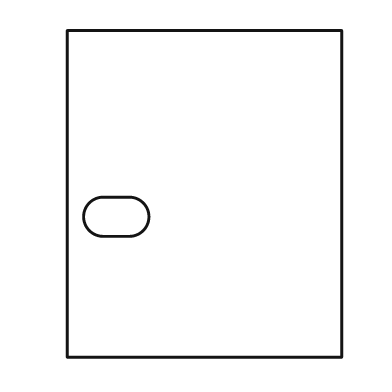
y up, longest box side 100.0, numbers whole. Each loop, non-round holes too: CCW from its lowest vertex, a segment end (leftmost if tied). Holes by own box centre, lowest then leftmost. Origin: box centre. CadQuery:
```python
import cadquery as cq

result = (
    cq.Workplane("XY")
    .moveTo(-42.0, -50.0)
    .lineTo(42.0, -50.0)
    .lineTo(42.0, 50.0)
    .lineTo(-42.0, 50.0)
    .close()
    .moveTo(-31.0, -13.0)
    .lineTo(-23.0, -13.0)
    .threePointArc((-17.0, -7.0), (-23.0, -1.0))
    .lineTo(-31.0, -1.0)
    .threePointArc((-37.0, -7.0), (-31.0, -13.0))
    .close()
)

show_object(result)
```